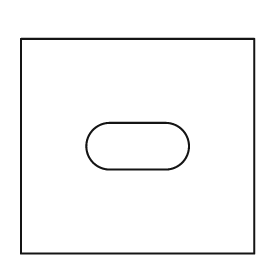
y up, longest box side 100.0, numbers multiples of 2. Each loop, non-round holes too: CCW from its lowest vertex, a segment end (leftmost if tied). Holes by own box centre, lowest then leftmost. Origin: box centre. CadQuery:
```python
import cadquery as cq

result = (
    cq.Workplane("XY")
    .moveTo(-50.0, -46.0)
    .lineTo(50.0, -46.0)
    .lineTo(50.0, 46.0)
    .lineTo(-50.0, 46.0)
    .close()
    .moveTo(-12.0, -10.0)
    .lineTo(12.0, -10.0)
    .threePointArc((22.0, 0.0), (12.0, 10.0))
    .lineTo(-12.0, 10.0)
    .threePointArc((-22.0, 0.0), (-12.0, -10.0))
    .close()
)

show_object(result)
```